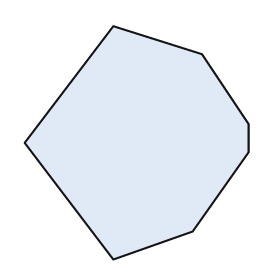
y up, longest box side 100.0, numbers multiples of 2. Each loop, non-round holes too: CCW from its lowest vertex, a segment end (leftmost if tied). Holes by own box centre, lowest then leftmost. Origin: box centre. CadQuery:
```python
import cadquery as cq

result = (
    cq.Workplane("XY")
    .moveTo(-10.0, -50.0)
    .lineTo(24.0, -38.0)
    .lineTo(48.0, -4.0)
    .lineTo(48.0, 8.0)
    .lineTo(28.0, 38.0)
    .lineTo(-10.0, 50.0)
    .lineTo(-48.0, 0.0)
    .close()
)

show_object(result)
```